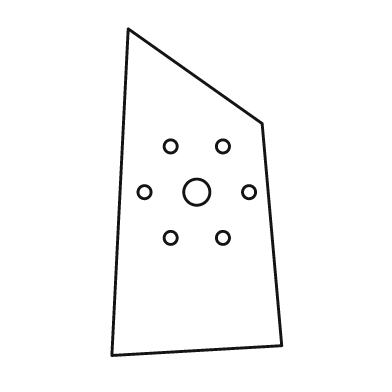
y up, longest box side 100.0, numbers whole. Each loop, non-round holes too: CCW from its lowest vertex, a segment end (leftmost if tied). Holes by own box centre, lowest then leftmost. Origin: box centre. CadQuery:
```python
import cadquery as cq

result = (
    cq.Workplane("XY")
    .moveTo(-26.0, -50.0)
    .lineTo(26.0, -47.0)
    .lineTo(20.0, 21.0)
    .lineTo(-21.0, 50.0)
    .close()
    .moveTo(-8.0, -14.0)
    .circle(2.0)
    .moveTo(8.0, -14.0)
    .circle(2.0)
    .moveTo(-16.0, 0.0)
    .circle(2.0)
    .moveTo(0.0, 0.0)
    .circle(4.0)
    .moveTo(16.0, 0.0)
    .circle(2.0)
    .moveTo(-8.0, 14.0)
    .circle(2.0)
    .moveTo(8.0, 14.0)
    .circle(2.0)
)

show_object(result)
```